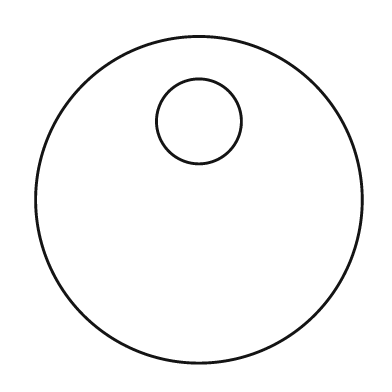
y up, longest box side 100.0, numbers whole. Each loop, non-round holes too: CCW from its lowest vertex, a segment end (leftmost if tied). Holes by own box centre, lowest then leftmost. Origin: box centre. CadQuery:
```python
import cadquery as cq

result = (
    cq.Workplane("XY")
    .moveTo(0.0, 0.0)
    .circle(50.0)
    .moveTo(0.0, 24.0)
    .circle(13.0)
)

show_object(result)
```